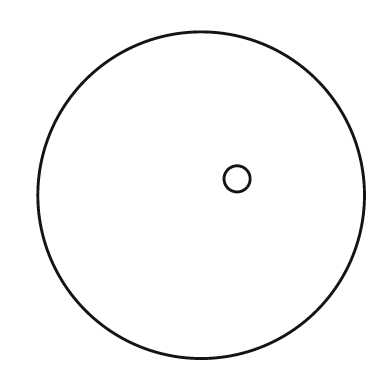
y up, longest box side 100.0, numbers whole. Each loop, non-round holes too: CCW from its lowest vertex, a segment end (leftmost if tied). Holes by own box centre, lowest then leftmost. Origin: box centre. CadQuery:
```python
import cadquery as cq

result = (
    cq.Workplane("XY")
    .moveTo(0.0, 0.0)
    .circle(50.0)
    .moveTo(11.0, 5.0)
    .circle(4.0)
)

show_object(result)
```